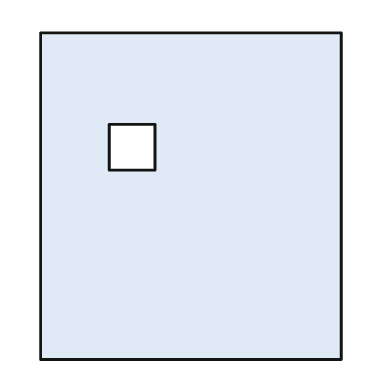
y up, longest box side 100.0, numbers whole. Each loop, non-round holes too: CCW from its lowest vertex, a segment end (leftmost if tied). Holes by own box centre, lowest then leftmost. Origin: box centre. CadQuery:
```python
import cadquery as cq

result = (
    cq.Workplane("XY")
    .moveTo(-46.0, -50.0)
    .lineTo(46.0, -50.0)
    .lineTo(46.0, 50.0)
    .lineTo(-46.0, 50.0)
    .close()
    .moveTo(-25.0, 8.0)
    .lineTo(-11.0, 8.0)
    .lineTo(-11.0, 22.0)
    .lineTo(-25.0, 22.0)
    .close()
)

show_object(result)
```